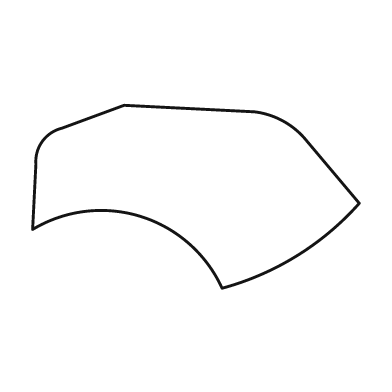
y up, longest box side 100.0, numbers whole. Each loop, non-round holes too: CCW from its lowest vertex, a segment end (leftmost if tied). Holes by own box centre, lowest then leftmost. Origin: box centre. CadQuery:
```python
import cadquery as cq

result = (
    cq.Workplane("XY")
    .moveTo(8.0, -28.0)
    .threePointArc((31.0, -18.0), (50.0, -2.0))
    .lineTo(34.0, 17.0)
    .threePointArc((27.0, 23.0), (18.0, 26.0))
    .lineTo(-22.0, 28.0)
    .lineTo(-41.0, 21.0)
    .threePointArc((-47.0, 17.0), (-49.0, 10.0))
    .lineTo(-50.0, -10.0)
    .threePointArc((-17.0, -6.0), (8.0, -28.0))
    .close()
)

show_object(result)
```